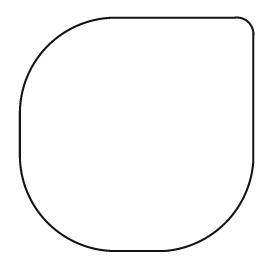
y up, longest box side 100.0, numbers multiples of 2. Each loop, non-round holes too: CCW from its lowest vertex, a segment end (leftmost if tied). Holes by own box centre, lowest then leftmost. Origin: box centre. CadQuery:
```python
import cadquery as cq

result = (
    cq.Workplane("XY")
    .moveTo(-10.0, -50.0)
    .lineTo(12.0, -50.0)
    .threePointArc((38.0, -38.0), (50.0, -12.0))
    .lineTo(50.0, 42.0)
    .threePointArc((48.0, 48.0), (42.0, 50.0))
    .lineTo(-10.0, 50.0)
    .threePointArc((-38.0, 38.0), (-50.0, 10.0))
    .lineTo(-50.0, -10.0)
    .threePointArc((-38.0, -38.0), (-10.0, -50.0))
    .close()
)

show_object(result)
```